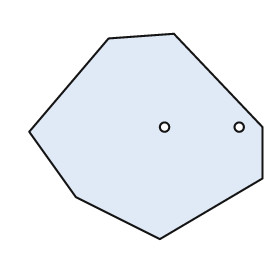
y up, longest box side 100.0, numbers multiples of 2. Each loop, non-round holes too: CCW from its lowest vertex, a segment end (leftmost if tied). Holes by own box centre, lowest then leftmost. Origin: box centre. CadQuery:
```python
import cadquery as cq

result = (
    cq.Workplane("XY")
    .moveTo(6.0, -44.0)
    .lineTo(50.0, -18.0)
    .lineTo(50.0, 4.0)
    .lineTo(12.0, 44.0)
    .lineTo(-16.0, 42.0)
    .lineTo(-50.0, 2.0)
    .lineTo(-30.0, -26.0)
    .close()
    .moveTo(8.0, 4.0)
    .circle(2.0)
    .moveTo(40.0, 4.0)
    .circle(2.0)
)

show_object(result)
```